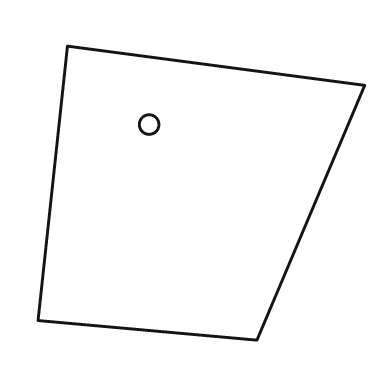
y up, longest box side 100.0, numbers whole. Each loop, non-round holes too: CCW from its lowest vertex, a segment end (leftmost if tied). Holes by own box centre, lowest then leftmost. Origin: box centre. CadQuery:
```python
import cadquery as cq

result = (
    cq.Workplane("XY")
    .moveTo(17.0, -45.0)
    .lineTo(50.0, 33.0)
    .lineTo(-41.0, 45.0)
    .lineTo(-50.0, -39.0)
    .close()
    .moveTo(-16.0, 21.0)
    .circle(3.0)
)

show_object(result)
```